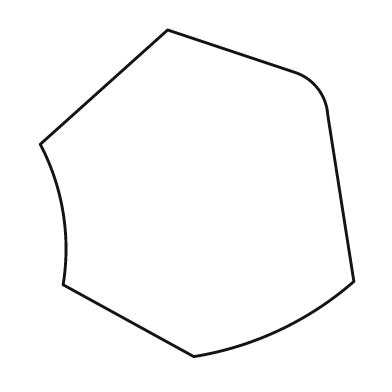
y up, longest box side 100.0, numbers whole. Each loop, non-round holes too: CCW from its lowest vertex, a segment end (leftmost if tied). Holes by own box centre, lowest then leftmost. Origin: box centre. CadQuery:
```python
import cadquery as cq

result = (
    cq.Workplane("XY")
    .moveTo(-1.0, -50.0)
    .threePointArc((25.0, -42.0), (48.0, -27.0))
    .lineTo(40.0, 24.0)
    .threePointArc((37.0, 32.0), (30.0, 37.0))
    .lineTo(-9.0, 50.0)
    .lineTo(-48.0, 15.0)
    .threePointArc((-41.0, -6.0), (-41.0, -28.0))
    .close()
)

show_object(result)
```